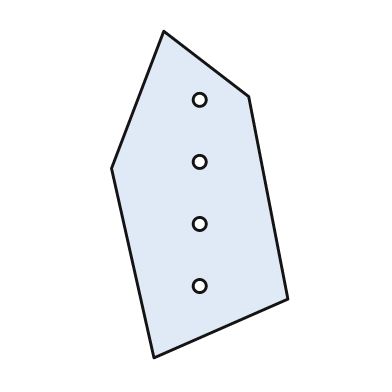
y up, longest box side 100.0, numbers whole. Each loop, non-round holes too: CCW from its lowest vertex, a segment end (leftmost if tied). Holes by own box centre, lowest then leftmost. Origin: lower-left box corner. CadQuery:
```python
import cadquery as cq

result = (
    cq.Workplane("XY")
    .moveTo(13.0, 0.0)
    .lineTo(54.0, 18.0)
    .lineTo(42.0, 80.0)
    .lineTo(16.0, 100.0)
    .lineTo(0.0, 58.0)
    .close()
    .moveTo(27.0, 22.0)
    .circle(2.0)
    .moveTo(27.0, 41.0)
    .circle(2.0)
    .moveTo(27.0, 60.0)
    .circle(2.0)
    .moveTo(27.0, 79.0)
    .circle(2.0)
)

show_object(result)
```